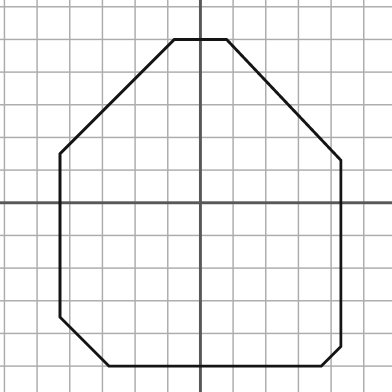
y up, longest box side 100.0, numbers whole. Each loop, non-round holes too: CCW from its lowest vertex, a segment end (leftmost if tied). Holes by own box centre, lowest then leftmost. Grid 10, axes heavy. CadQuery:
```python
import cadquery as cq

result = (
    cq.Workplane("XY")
    .moveTo(-28.0, -50.0)
    .lineTo(37.0, -50.0)
    .lineTo(43.0, -44.0)
    .lineTo(43.0, 13.0)
    .lineTo(8.0, 50.0)
    .lineTo(-8.0, 50.0)
    .lineTo(-43.0, 15.0)
    .lineTo(-43.0, -35.0)
    .close()
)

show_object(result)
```